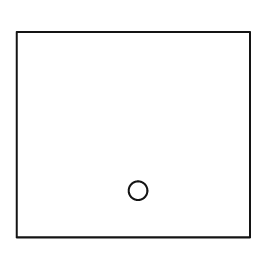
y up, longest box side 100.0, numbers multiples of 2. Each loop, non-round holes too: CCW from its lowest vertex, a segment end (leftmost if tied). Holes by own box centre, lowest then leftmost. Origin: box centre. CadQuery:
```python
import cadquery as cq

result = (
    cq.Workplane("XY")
    .moveTo(-50.0, -44.0)
    .lineTo(50.0, -44.0)
    .lineTo(50.0, 44.0)
    .lineTo(-50.0, 44.0)
    .close()
    .moveTo(2.0, -24.0)
    .circle(4.0)
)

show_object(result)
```